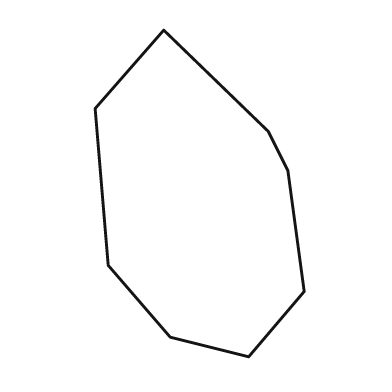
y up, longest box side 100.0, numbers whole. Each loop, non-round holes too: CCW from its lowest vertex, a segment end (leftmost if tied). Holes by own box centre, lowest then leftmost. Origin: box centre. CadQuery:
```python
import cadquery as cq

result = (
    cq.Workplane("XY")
    .moveTo(15.0, -50.0)
    .lineTo(32.0, -30.0)
    .lineTo(27.0, 7.0)
    .lineTo(21.0, 19.0)
    .lineTo(-11.0, 50.0)
    .lineTo(-32.0, 26.0)
    .lineTo(-28.0, -22.0)
    .lineTo(-9.0, -44.0)
    .close()
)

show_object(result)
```